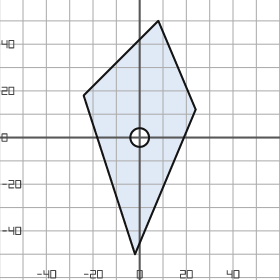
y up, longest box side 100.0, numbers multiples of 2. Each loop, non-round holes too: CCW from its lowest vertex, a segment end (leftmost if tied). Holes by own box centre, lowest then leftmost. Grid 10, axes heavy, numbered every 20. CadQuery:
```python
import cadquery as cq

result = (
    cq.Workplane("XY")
    .moveTo(-2.0, -50.0)
    .lineTo(24.0, 12.0)
    .lineTo(8.0, 50.0)
    .lineTo(-24.0, 18.0)
    .close()
    .moveTo(0.0, 0.0)
    .circle(4.0)
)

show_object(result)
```